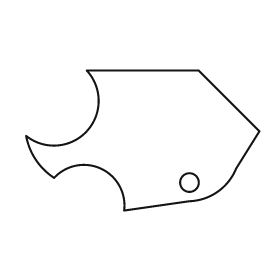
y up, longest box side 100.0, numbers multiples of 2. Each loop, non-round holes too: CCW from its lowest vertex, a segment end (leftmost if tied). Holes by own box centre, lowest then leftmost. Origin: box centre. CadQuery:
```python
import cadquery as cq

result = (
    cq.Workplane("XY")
    .moveTo(-8.0, -30.0)
    .lineTo(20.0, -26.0)
    .threePointArc((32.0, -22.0), (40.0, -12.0))
    .lineTo(50.0, 4.0)
    .lineTo(24.0, 30.0)
    .lineTo(-24.0, 30.0)
    .threePointArc((-24.0, 4.0), (-50.0, 2.0))
    .threePointArc((-46.0, -8.0), (-38.0, -16.0))
    .threePointArc((-18.0, -12.0), (-8.0, -30.0))
    .close()
    .moveTo(20.0, -18.0)
    .circle(4.0)
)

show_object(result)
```